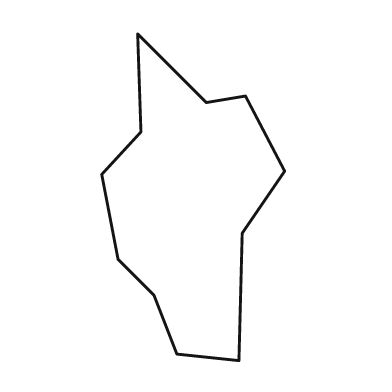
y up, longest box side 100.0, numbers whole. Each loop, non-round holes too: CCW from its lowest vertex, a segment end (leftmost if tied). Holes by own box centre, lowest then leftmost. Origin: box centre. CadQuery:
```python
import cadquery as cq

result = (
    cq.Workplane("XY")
    .moveTo(14.0, -50.0)
    .lineTo(15.0, -11.0)
    .lineTo(28.0, 8.0)
    .lineTo(16.0, 31.0)
    .lineTo(4.0, 29.0)
    .lineTo(-17.0, 50.0)
    .lineTo(-16.0, 20.0)
    .lineTo(-28.0, 7.0)
    .lineTo(-23.0, -19.0)
    .lineTo(-12.0, -30.0)
    .lineTo(-5.0, -48.0)
    .close()
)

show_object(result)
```